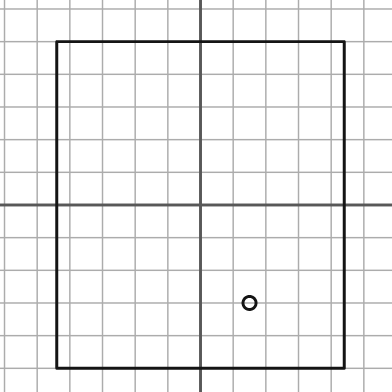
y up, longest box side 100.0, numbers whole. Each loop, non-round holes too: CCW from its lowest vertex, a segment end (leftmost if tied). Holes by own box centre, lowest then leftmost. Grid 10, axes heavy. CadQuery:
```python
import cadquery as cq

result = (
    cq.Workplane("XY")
    .moveTo(-44.0, -50.0)
    .lineTo(44.0, -50.0)
    .lineTo(44.0, 50.0)
    .lineTo(-44.0, 50.0)
    .close()
    .moveTo(15.0, -30.0)
    .circle(2.0)
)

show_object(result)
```